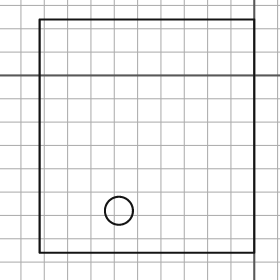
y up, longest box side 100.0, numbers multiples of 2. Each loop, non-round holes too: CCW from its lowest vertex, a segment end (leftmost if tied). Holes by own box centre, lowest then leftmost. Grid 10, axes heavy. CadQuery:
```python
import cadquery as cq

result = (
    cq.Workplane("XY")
    .moveTo(-92.0, -76.0)
    .lineTo(0.0, -76.0)
    .lineTo(0.0, 24.0)
    .lineTo(-92.0, 24.0)
    .close()
    .moveTo(-58.0, -58.0)
    .circle(6.0)
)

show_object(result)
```